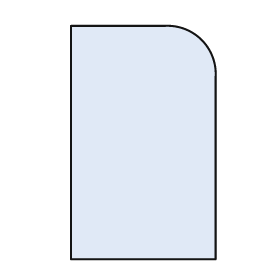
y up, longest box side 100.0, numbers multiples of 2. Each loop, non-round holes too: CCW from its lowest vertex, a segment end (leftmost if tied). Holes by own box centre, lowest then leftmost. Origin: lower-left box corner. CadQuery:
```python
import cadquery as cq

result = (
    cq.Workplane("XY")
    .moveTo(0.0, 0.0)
    .lineTo(62.0, 0.0)
    .lineTo(62.0, 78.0)
    .threePointArc((56.0, 94.0), (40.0, 100.0))
    .lineTo(0.0, 100.0)
    .close()
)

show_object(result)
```